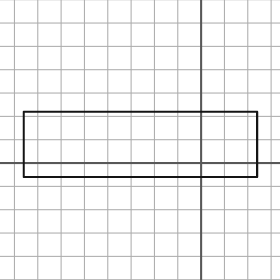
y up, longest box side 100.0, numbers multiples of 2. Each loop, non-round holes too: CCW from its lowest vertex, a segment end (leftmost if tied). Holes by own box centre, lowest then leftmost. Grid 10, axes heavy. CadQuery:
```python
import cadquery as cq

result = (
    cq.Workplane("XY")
    .moveTo(-76.0, -6.0)
    .lineTo(24.0, -6.0)
    .lineTo(24.0, 22.0)
    .lineTo(-76.0, 22.0)
    .close()
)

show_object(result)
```